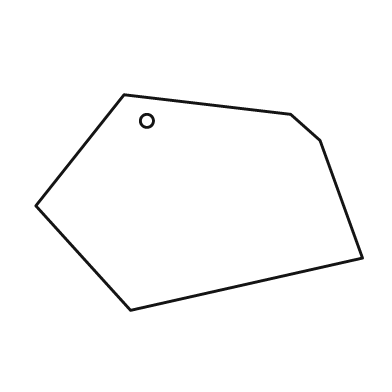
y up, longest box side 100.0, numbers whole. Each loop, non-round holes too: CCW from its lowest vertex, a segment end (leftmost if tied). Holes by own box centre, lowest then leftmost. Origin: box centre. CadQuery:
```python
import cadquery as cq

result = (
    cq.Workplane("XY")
    .moveTo(-21.0, -33.0)
    .lineTo(50.0, -17.0)
    .lineTo(37.0, 19.0)
    .lineTo(28.0, 27.0)
    .lineTo(-23.0, 33.0)
    .lineTo(-50.0, -1.0)
    .close()
    .moveTo(-16.0, 25.0)
    .circle(2.0)
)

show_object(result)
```